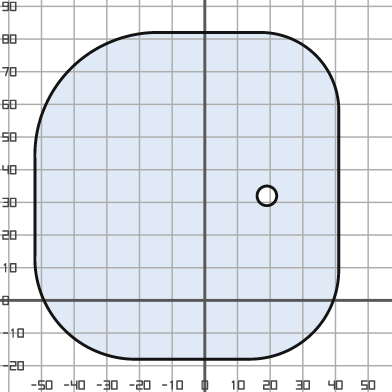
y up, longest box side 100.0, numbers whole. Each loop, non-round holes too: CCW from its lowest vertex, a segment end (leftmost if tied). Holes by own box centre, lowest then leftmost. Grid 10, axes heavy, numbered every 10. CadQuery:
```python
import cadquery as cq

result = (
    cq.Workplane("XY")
    .moveTo(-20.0, -18.0)
    .lineTo(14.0, -18.0)
    .threePointArc((33.0, -10.0), (41.0, 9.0))
    .lineTo(41.0, 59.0)
    .threePointArc((34.0, 75.0), (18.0, 82.0))
    .lineTo(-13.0, 82.0)
    .threePointArc((-41.0, 71.0), (-52.0, 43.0))
    .lineTo(-52.0, 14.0)
    .threePointArc((-43.0, -9.0), (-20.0, -18.0))
    .close()
    .moveTo(19.0, 32.0)
    .circle(3.0)
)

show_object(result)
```